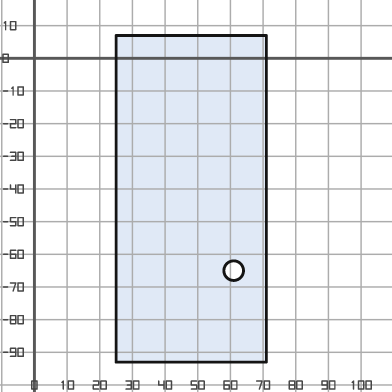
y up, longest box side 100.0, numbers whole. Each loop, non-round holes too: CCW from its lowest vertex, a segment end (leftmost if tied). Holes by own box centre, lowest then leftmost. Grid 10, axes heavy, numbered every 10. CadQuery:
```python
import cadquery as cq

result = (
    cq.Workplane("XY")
    .moveTo(25.0, -93.0)
    .lineTo(71.0, -93.0)
    .lineTo(71.0, 7.0)
    .lineTo(25.0, 7.0)
    .close()
    .moveTo(61.0, -65.0)
    .circle(3.0)
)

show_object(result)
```